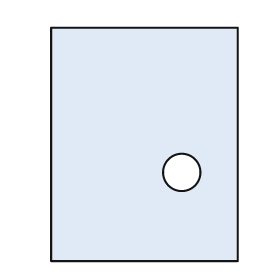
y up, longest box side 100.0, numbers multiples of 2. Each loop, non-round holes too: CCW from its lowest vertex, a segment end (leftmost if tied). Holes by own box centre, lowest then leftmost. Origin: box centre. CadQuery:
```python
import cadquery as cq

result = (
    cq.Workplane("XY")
    .moveTo(-40.0, -50.0)
    .lineTo(40.0, -50.0)
    .lineTo(40.0, 50.0)
    .lineTo(-40.0, 50.0)
    .close()
    .moveTo(16.0, -12.0)
    .circle(8.0)
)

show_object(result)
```